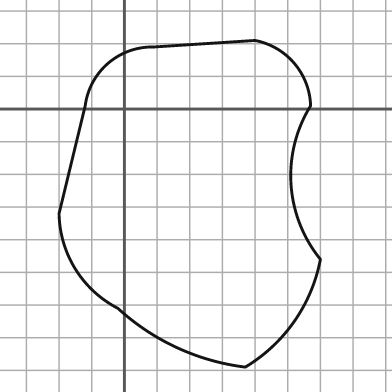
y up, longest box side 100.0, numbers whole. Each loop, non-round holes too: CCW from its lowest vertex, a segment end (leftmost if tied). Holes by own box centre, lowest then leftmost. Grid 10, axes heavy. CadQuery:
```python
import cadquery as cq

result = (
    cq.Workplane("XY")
    .moveTo(37.0, -79.0)
    .threePointArc((52.0, -65.0), (60.0, -46.0))
    .threePointArc((51.0, -23.0), (57.0, 1.0))
    .threePointArc((52.0, 14.0), (40.0, 21.0))
    .lineTo(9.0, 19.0)
    .threePointArc((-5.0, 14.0), (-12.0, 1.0))
    .lineTo(-20.0, -32.0)
    .threePointArc((-15.0, -49.0), (-2.0, -61.0))
    .threePointArc((16.0, -73.0), (37.0, -79.0))
    .close()
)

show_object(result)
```